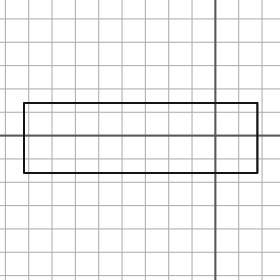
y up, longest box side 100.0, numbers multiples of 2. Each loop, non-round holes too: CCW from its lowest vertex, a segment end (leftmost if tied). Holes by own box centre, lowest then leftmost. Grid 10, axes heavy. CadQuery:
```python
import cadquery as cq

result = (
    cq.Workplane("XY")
    .moveTo(-82.0, -16.0)
    .lineTo(18.0, -16.0)
    .lineTo(18.0, 14.0)
    .lineTo(-82.0, 14.0)
    .close()
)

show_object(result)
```